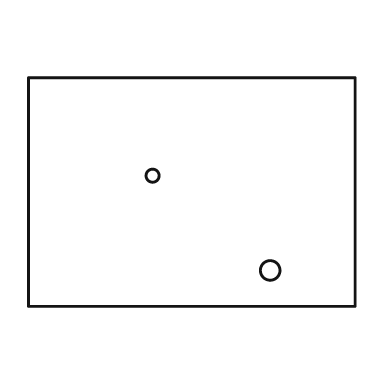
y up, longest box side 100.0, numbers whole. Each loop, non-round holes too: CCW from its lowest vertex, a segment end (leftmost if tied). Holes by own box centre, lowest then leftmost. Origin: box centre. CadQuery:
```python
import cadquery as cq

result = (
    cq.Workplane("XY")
    .moveTo(-50.0, -35.0)
    .lineTo(50.0, -35.0)
    .lineTo(50.0, 35.0)
    .lineTo(-50.0, 35.0)
    .close()
    .moveTo(24.0, -24.0)
    .circle(3.0)
    .moveTo(-12.0, 5.0)
    .circle(2.0)
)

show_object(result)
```